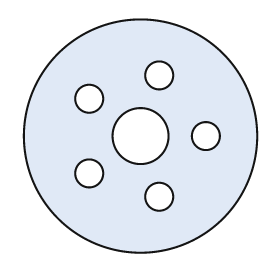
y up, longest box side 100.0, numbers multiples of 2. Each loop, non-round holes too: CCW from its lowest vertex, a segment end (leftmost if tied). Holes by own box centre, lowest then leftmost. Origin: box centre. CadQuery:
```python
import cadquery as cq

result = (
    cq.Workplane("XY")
    .moveTo(0.0, 0.0)
    .circle(50.0)
    .moveTo(8.0, -26.0)
    .circle(6.0)
    .moveTo(-22.0, -16.0)
    .circle(6.0)
    .moveTo(0.0, 0.0)
    .circle(12.0)
    .moveTo(28.0, 0.0)
    .circle(6.0)
    .moveTo(-22.0, 16.0)
    .circle(6.0)
    .moveTo(8.0, 26.0)
    .circle(6.0)
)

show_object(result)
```